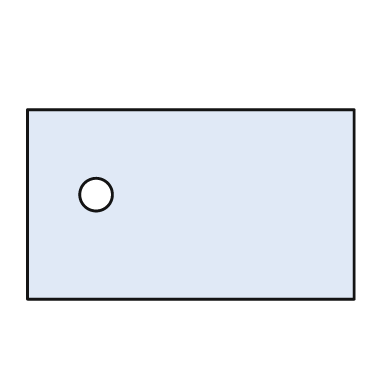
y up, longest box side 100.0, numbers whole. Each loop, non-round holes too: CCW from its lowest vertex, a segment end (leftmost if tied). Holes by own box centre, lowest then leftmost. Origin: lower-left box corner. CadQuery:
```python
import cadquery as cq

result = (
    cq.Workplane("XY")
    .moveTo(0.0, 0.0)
    .lineTo(100.0, 0.0)
    .lineTo(100.0, 58.0)
    .lineTo(0.0, 58.0)
    .close()
    .moveTo(21.0, 32.0)
    .circle(5.0)
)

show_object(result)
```